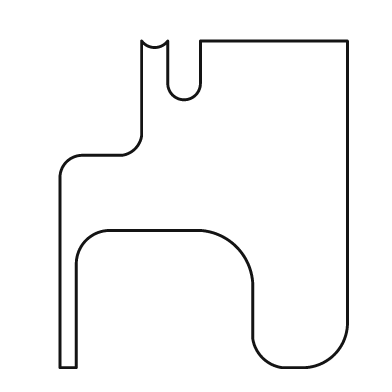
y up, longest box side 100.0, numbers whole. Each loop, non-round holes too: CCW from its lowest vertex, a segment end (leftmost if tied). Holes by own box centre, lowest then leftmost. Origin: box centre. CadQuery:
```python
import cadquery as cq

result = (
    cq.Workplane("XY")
    .moveTo(-44.0, -50.0)
    .lineTo(-39.0, -50.0)
    .lineTo(-39.0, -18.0)
    .threePointArc((-36.0, -11.0), (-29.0, -8.0))
    .lineTo(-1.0, -8.0)
    .threePointArc((10.0, -13.0), (15.0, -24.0))
    .lineTo(15.0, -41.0)
    .threePointArc((18.0, -47.0), (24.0, -50.0))
    .lineTo(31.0, -50.0)
    .threePointArc((40.0, -46.0), (44.0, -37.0))
    .lineTo(44.0, 50.0)
    .lineTo(-1.0, 50.0)
    .lineTo(-1.0, 37.0)
    .threePointArc((-6.0, 32.0), (-11.0, 37.0))
    .lineTo(-11.0, 50.0)
    .threePointArc((-15.0, 48.0), (-19.0, 50.0))
    .lineTo(-19.0, 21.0)
    .threePointArc((-21.0, 17.0), (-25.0, 15.0))
    .lineTo(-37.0, 15.0)
    .threePointArc((-42.0, 13.0), (-44.0, 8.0))
    .close()
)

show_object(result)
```